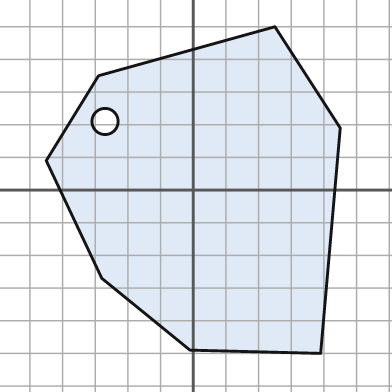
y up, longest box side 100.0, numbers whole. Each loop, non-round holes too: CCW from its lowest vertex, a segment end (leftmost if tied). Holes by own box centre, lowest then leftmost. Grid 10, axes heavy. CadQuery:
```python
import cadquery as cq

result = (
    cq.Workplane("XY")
    .moveTo(39.0, -50.0)
    .lineTo(45.0, 19.0)
    .lineTo(25.0, 50.0)
    .lineTo(-29.0, 35.0)
    .lineTo(-45.0, 9.0)
    .lineTo(-28.0, -27.0)
    .lineTo(-1.0, -49.0)
    .close()
    .moveTo(-27.0, 21.0)
    .circle(4.0)
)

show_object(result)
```